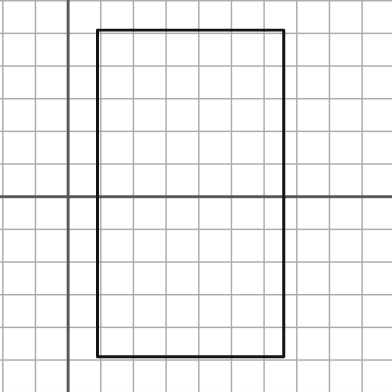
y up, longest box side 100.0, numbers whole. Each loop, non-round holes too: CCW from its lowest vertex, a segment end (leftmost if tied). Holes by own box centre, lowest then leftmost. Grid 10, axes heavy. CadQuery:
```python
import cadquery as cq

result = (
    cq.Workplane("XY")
    .moveTo(9.0, -49.0)
    .lineTo(66.0, -49.0)
    .lineTo(66.0, 51.0)
    .lineTo(9.0, 51.0)
    .close()
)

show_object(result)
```